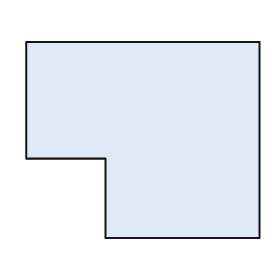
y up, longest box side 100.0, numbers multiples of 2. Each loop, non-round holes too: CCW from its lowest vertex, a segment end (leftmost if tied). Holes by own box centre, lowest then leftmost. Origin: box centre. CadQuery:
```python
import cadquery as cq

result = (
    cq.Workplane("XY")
    .moveTo(-16.0, -42.0)
    .lineTo(50.0, -42.0)
    .lineTo(50.0, 42.0)
    .lineTo(-50.0, 42.0)
    .lineTo(-50.0, -8.0)
    .lineTo(-16.0, -8.0)
    .close()
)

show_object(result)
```